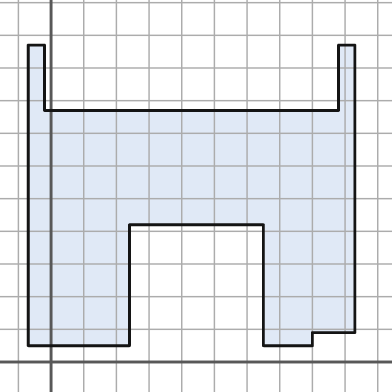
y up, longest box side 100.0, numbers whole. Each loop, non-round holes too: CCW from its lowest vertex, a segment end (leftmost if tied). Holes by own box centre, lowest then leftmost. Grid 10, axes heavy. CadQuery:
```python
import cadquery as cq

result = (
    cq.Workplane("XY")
    .moveTo(-7.0, 5.0)
    .lineTo(24.0, 5.0)
    .lineTo(24.0, 42.0)
    .lineTo(65.0, 42.0)
    .lineTo(65.0, 5.0)
    .lineTo(80.0, 5.0)
    .lineTo(80.0, 9.0)
    .lineTo(93.0, 9.0)
    .lineTo(93.0, 97.0)
    .lineTo(88.0, 97.0)
    .lineTo(88.0, 77.0)
    .lineTo(-2.0, 77.0)
    .lineTo(-2.0, 97.0)
    .lineTo(-7.0, 97.0)
    .close()
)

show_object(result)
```